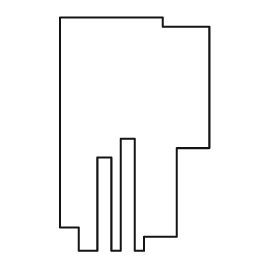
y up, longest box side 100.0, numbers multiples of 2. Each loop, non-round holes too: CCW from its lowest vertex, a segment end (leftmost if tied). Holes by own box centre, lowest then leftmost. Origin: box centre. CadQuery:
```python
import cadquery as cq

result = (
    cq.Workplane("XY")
    .moveTo(-24.0, -50.0)
    .lineTo(-16.0, -50.0)
    .lineTo(-16.0, -10.0)
    .lineTo(-10.0, -10.0)
    .lineTo(-10.0, -50.0)
    .lineTo(-6.0, -50.0)
    .lineTo(-6.0, -2.0)
    .lineTo(0.0, -2.0)
    .lineTo(0.0, -50.0)
    .lineTo(4.0, -50.0)
    .lineTo(4.0, -44.0)
    .lineTo(18.0, -44.0)
    .lineTo(18.0, -6.0)
    .lineTo(32.0, -6.0)
    .lineTo(32.0, 46.0)
    .lineTo(12.0, 46.0)
    .lineTo(12.0, 50.0)
    .lineTo(-32.0, 50.0)
    .lineTo(-32.0, -40.0)
    .lineTo(-24.0, -40.0)
    .close()
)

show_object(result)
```